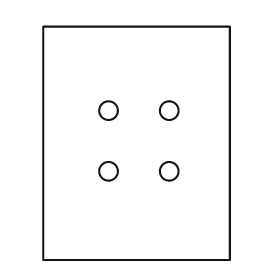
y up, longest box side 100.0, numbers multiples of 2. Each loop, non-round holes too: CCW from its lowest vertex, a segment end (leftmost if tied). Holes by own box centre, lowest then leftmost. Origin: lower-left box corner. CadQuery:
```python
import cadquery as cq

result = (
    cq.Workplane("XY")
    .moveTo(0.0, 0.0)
    .lineTo(80.0, 0.0)
    .lineTo(80.0, 100.0)
    .lineTo(0.0, 100.0)
    .close()
    .moveTo(28.0, 38.0)
    .circle(4.0)
    .moveTo(54.0, 38.0)
    .circle(4.0)
    .moveTo(28.0, 64.0)
    .circle(4.0)
    .moveTo(54.0, 64.0)
    .circle(4.0)
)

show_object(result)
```